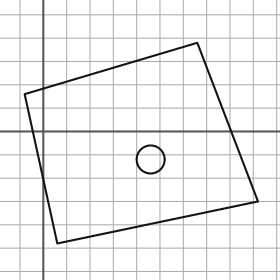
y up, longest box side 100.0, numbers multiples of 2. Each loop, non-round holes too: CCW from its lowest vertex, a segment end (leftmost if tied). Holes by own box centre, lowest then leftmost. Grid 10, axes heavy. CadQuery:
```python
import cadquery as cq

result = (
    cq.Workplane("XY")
    .moveTo(6.0, -48.0)
    .lineTo(92.0, -30.0)
    .lineTo(66.0, 38.0)
    .lineTo(-8.0, 16.0)
    .close()
    .moveTo(46.0, -12.0)
    .circle(6.0)
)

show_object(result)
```